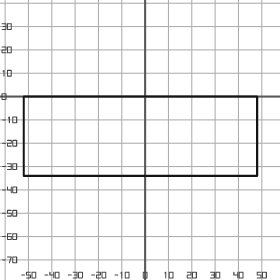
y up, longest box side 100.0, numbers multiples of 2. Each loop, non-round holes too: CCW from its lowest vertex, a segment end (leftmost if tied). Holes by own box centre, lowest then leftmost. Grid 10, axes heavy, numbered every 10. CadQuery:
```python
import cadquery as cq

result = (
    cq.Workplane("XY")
    .moveTo(-52.0, -34.0)
    .lineTo(48.0, -34.0)
    .lineTo(48.0, 0.0)
    .lineTo(-52.0, 0.0)
    .close()
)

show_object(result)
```